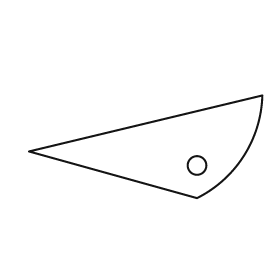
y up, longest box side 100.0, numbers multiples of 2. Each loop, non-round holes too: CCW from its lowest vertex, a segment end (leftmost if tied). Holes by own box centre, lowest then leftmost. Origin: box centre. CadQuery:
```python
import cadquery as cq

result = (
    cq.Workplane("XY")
    .moveTo(22.0, -22.0)
    .threePointArc((42.0, -4.0), (50.0, 22.0))
    .lineTo(-50.0, -2.0)
    .close()
    .moveTo(22.0, -8.0)
    .circle(4.0)
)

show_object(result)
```